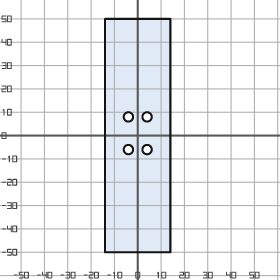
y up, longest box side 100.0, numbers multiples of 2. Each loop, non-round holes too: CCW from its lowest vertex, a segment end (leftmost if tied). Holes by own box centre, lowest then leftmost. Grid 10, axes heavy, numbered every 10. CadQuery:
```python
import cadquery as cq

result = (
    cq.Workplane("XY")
    .moveTo(-14.0, -50.0)
    .lineTo(14.0, -50.0)
    .lineTo(14.0, 50.0)
    .lineTo(-14.0, 50.0)
    .close()
    .moveTo(-4.0, -6.0)
    .circle(2.0)
    .moveTo(4.0, -6.0)
    .circle(2.0)
    .moveTo(-4.0, 8.0)
    .circle(2.0)
    .moveTo(4.0, 8.0)
    .circle(2.0)
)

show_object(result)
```